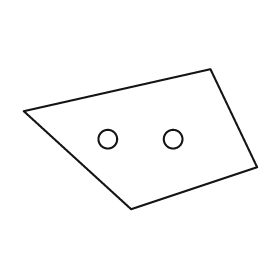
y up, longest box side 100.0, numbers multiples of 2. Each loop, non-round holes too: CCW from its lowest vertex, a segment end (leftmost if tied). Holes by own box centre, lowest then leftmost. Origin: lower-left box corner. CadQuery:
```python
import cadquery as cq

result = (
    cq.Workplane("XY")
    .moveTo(46.0, 0.0)
    .lineTo(100.0, 18.0)
    .lineTo(80.0, 60.0)
    .lineTo(0.0, 42.0)
    .close()
    .moveTo(36.0, 30.0)
    .circle(4.0)
    .moveTo(64.0, 30.0)
    .circle(4.0)
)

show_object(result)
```